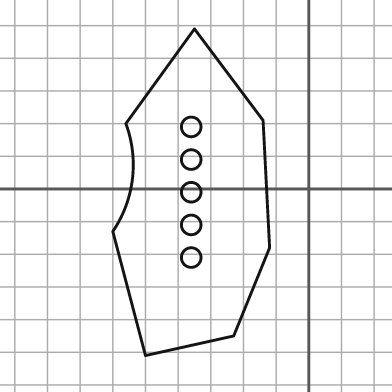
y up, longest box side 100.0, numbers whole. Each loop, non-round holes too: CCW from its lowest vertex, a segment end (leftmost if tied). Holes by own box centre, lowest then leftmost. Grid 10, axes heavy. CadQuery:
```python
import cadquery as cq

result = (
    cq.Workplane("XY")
    .moveTo(-50.0, -51.0)
    .lineTo(-23.0, -45.0)
    .lineTo(-12.0, -18.0)
    .lineTo(-14.0, 21.0)
    .lineTo(-35.0, 49.0)
    .lineTo(-56.0, 20.0)
    .threePointArc((-54.0, 3.0), (-60.0, -13.0))
    .close()
    .moveTo(-36.0, -21.0)
    .circle(3.0)
    .moveTo(-36.0, -11.0)
    .circle(3.0)
    .moveTo(-36.0, -1.0)
    .circle(3.0)
    .moveTo(-36.0, 9.0)
    .circle(3.0)
    .moveTo(-36.0, 19.0)
    .circle(3.0)
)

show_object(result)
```